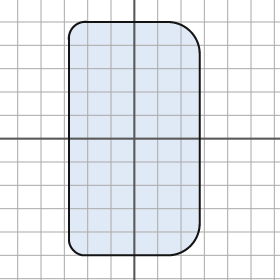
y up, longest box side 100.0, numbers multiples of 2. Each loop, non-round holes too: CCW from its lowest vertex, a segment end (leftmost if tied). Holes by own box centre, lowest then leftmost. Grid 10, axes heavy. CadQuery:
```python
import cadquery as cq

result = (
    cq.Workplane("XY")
    .moveTo(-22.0, -50.0)
    .lineTo(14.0, -50.0)
    .threePointArc((24.0, -46.0), (28.0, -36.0))
    .lineTo(28.0, 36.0)
    .threePointArc((24.0, 46.0), (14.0, 50.0))
    .lineTo(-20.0, 50.0)
    .threePointArc((-26.0, 48.0), (-28.0, 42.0))
    .lineTo(-28.0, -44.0)
    .threePointArc((-26.0, -48.0), (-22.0, -50.0))
    .close()
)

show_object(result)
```